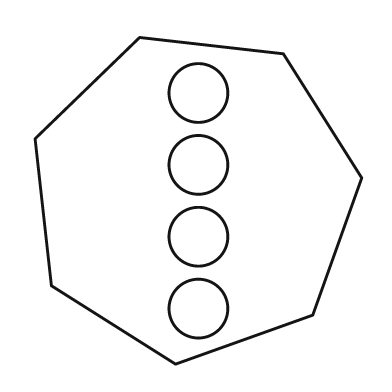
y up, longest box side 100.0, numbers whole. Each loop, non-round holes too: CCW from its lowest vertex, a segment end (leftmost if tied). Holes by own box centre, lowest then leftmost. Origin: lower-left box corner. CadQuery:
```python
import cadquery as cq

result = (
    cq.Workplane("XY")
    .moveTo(43.0, 0.0)
    .lineTo(85.0, 15.0)
    .lineTo(100.0, 57.0)
    .lineTo(76.0, 95.0)
    .lineTo(32.0, 100.0)
    .lineTo(0.0, 69.0)
    .lineTo(5.0, 24.0)
    .close()
    .moveTo(50.0, 17.0)
    .circle(9.0)
    .moveTo(50.0, 39.0)
    .circle(9.0)
    .moveTo(50.0, 61.0)
    .circle(9.0)
    .moveTo(50.0, 83.0)
    .circle(9.0)
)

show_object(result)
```